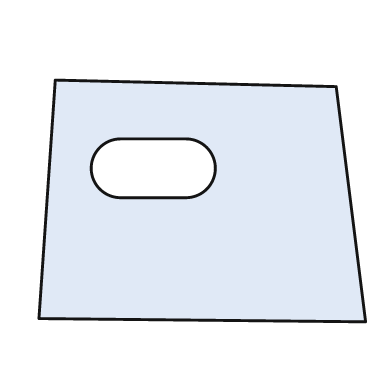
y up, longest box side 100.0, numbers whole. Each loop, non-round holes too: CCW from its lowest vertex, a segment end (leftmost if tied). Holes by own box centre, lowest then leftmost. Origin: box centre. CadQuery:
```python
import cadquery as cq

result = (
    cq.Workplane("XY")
    .moveTo(50.0, -37.0)
    .lineTo(41.0, 35.0)
    .lineTo(-45.0, 37.0)
    .lineTo(-50.0, -36.0)
    .close()
    .moveTo(-25.0, 1.0)
    .lineTo(-5.0, 1.0)
    .threePointArc((4.0, 10.0), (-5.0, 19.0))
    .lineTo(-25.0, 19.0)
    .threePointArc((-34.0, 10.0), (-25.0, 1.0))
    .close()
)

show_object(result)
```